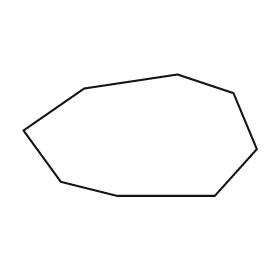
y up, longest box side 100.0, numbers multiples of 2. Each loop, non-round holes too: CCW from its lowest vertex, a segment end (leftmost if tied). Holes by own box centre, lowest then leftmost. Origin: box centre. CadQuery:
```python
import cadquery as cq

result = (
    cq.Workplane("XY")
    .moveTo(-10.0, -26.0)
    .lineTo(32.0, -26.0)
    .lineTo(50.0, -6.0)
    .lineTo(40.0, 18.0)
    .lineTo(16.0, 26.0)
    .lineTo(-24.0, 20.0)
    .lineTo(-50.0, 2.0)
    .lineTo(-34.0, -20.0)
    .close()
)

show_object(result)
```